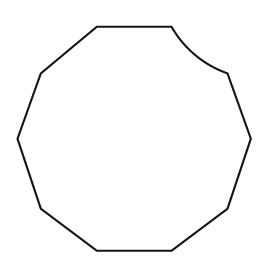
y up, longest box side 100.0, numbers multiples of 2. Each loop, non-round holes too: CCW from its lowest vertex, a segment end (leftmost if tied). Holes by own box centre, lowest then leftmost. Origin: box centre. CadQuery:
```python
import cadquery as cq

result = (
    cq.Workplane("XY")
    .moveTo(-16.0, -48.0)
    .lineTo(16.0, -48.0)
    .lineTo(40.0, -30.0)
    .lineTo(50.0, 0.0)
    .lineTo(40.0, 28.0)
    .threePointArc((26.0, 36.0), (16.0, 48.0))
    .lineTo(-16.0, 48.0)
    .lineTo(-40.0, 28.0)
    .lineTo(-50.0, 0.0)
    .lineTo(-40.0, -30.0)
    .close()
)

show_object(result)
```